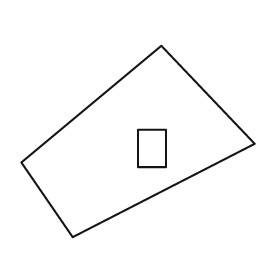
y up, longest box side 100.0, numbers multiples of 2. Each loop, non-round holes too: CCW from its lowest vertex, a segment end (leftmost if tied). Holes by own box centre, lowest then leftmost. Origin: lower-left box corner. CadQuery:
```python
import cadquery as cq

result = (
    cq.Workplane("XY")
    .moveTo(22.0, 0.0)
    .lineTo(100.0, 40.0)
    .lineTo(60.0, 82.0)
    .lineTo(0.0, 32.0)
    .close()
    .moveTo(50.0, 30.0)
    .lineTo(62.0, 30.0)
    .lineTo(62.0, 46.0)
    .lineTo(50.0, 46.0)
    .close()
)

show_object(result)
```